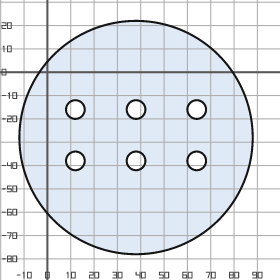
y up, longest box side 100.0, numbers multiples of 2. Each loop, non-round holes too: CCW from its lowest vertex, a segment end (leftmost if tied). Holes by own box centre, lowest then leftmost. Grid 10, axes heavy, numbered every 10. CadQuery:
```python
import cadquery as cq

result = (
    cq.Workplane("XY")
    .moveTo(38.0, -28.0)
    .circle(50.0)
    .moveTo(12.0, -38.0)
    .circle(4.0)
    .moveTo(38.0, -38.0)
    .circle(4.0)
    .moveTo(64.0, -38.0)
    .circle(4.0)
    .moveTo(12.0, -16.0)
    .circle(4.0)
    .moveTo(38.0, -16.0)
    .circle(4.0)
    .moveTo(64.0, -16.0)
    .circle(4.0)
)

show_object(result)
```